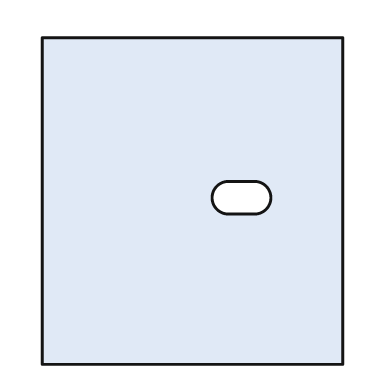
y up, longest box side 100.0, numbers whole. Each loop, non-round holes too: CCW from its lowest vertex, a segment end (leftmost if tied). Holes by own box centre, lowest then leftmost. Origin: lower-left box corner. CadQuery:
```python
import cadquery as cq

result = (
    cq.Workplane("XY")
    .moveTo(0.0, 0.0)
    .lineTo(92.0, 0.0)
    .lineTo(92.0, 100.0)
    .lineTo(0.0, 100.0)
    .close()
    .moveTo(57.0, 46.0)
    .lineTo(65.0, 46.0)
    .threePointArc((70.0, 51.0), (65.0, 56.0))
    .lineTo(57.0, 56.0)
    .threePointArc((52.0, 51.0), (57.0, 46.0))
    .close()
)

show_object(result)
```